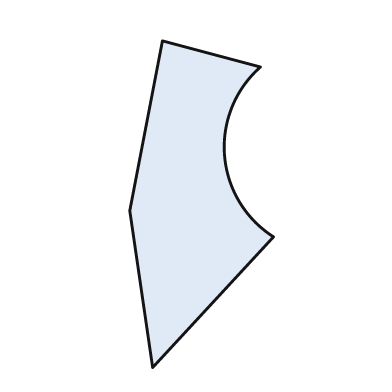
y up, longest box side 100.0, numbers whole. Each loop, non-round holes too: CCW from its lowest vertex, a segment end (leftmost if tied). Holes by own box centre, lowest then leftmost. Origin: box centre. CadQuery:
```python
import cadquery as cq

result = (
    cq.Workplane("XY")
    .moveTo(-15.0, -50.0)
    .lineTo(22.0, -10.0)
    .threePointArc((7.0, 15.0), (18.0, 42.0))
    .lineTo(-12.0, 50.0)
    .lineTo(-22.0, -2.0)
    .close()
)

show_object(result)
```